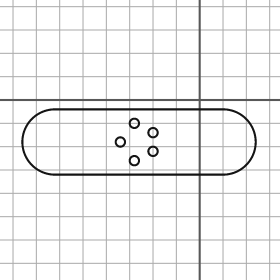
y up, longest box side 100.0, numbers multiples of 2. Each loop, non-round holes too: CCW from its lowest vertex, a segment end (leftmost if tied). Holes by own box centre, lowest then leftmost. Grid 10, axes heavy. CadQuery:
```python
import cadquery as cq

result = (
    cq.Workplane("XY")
    .moveTo(-62.0, -32.0)
    .lineTo(10.0, -32.0)
    .threePointArc((24.0, -18.0), (10.0, -4.0))
    .lineTo(-62.0, -4.0)
    .threePointArc((-76.0, -18.0), (-62.0, -32.0))
    .close()
    .moveTo(-28.0, -26.0)
    .circle(2.0)
    .moveTo(-20.0, -22.0)
    .circle(2.0)
    .moveTo(-34.0, -18.0)
    .circle(2.0)
    .moveTo(-20.0, -14.0)
    .circle(2.0)
    .moveTo(-28.0, -10.0)
    .circle(2.0)
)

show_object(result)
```